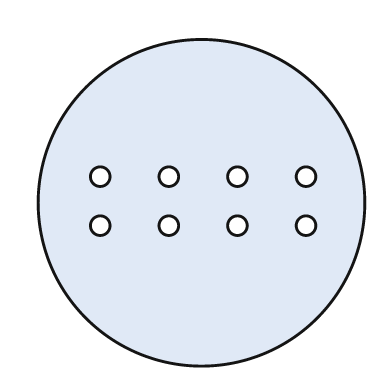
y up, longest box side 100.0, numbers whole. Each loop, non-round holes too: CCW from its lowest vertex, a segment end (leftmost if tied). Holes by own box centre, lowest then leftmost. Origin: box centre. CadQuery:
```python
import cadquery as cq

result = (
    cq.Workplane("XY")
    .moveTo(0.0, 0.0)
    .circle(50.0)
    .moveTo(-31.0, -7.0)
    .circle(3.0)
    .moveTo(-10.0, -7.0)
    .circle(3.0)
    .moveTo(11.0, -7.0)
    .circle(3.0)
    .moveTo(32.0, -7.0)
    .circle(3.0)
    .moveTo(-31.0, 8.0)
    .circle(3.0)
    .moveTo(-10.0, 8.0)
    .circle(3.0)
    .moveTo(11.0, 8.0)
    .circle(3.0)
    .moveTo(32.0, 8.0)
    .circle(3.0)
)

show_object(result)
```